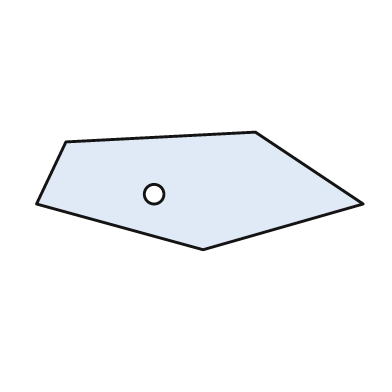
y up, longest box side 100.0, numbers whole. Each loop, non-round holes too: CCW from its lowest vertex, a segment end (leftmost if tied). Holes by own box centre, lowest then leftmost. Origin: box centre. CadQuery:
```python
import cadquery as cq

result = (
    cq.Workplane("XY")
    .moveTo(1.0, -18.0)
    .lineTo(50.0, -4.0)
    .lineTo(17.0, 18.0)
    .lineTo(-41.0, 15.0)
    .lineTo(-50.0, -4.0)
    .close()
    .moveTo(-14.0, -1.0)
    .circle(3.0)
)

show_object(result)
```